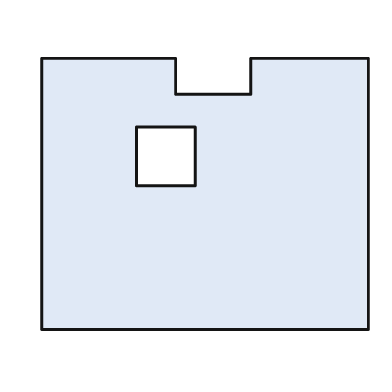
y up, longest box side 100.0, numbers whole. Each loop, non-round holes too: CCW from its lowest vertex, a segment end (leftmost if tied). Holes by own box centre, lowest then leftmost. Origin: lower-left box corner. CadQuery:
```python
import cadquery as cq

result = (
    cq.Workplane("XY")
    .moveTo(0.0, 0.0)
    .lineTo(100.0, 0.0)
    .lineTo(100.0, 83.0)
    .lineTo(64.0, 83.0)
    .lineTo(64.0, 72.0)
    .lineTo(41.0, 72.0)
    .lineTo(41.0, 83.0)
    .lineTo(0.0, 83.0)
    .close()
    .moveTo(29.0, 44.0)
    .lineTo(47.0, 44.0)
    .lineTo(47.0, 62.0)
    .lineTo(29.0, 62.0)
    .close()
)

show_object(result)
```